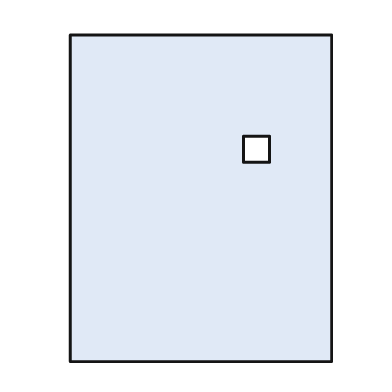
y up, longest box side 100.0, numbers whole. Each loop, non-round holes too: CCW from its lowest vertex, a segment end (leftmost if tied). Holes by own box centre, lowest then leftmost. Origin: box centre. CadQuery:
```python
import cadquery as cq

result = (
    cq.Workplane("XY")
    .moveTo(-40.0, -50.0)
    .lineTo(40.0, -50.0)
    .lineTo(40.0, 50.0)
    .lineTo(-40.0, 50.0)
    .close()
    .moveTo(13.0, 11.0)
    .lineTo(21.0, 11.0)
    .lineTo(21.0, 19.0)
    .lineTo(13.0, 19.0)
    .close()
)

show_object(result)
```